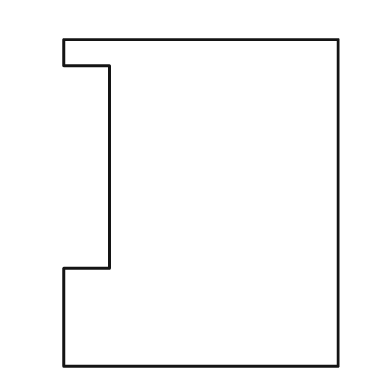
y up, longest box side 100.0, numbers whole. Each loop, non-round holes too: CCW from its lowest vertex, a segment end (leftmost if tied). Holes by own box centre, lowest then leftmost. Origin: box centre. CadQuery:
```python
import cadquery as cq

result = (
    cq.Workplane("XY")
    .moveTo(-42.0, -50.0)
    .lineTo(42.0, -50.0)
    .lineTo(42.0, 50.0)
    .lineTo(-42.0, 50.0)
    .lineTo(-42.0, 42.0)
    .lineTo(-28.0, 42.0)
    .lineTo(-28.0, -20.0)
    .lineTo(-42.0, -20.0)
    .close()
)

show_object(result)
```